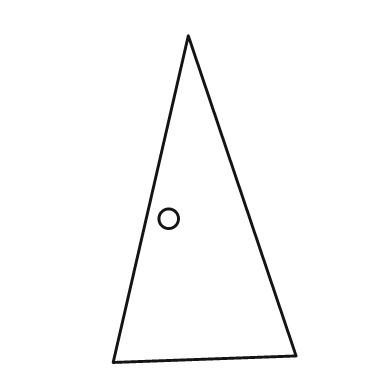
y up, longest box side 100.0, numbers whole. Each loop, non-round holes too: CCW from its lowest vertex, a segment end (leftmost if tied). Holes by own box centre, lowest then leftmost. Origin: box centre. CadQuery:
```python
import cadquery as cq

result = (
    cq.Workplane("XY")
    .moveTo(-28.0, -50.0)
    .lineTo(28.0, -48.0)
    .lineTo(-5.0, 50.0)
    .close()
    .moveTo(-11.0, -6.0)
    .circle(3.0)
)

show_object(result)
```